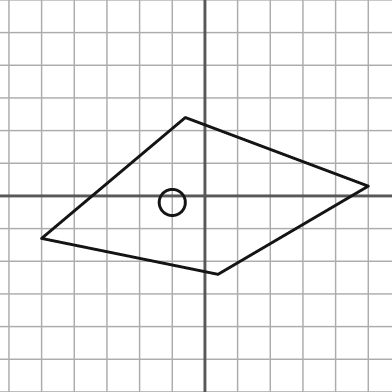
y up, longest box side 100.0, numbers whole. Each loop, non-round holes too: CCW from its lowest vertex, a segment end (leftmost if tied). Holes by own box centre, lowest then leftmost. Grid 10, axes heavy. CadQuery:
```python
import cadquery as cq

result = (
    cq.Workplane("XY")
    .moveTo(4.0, -24.0)
    .lineTo(50.0, 3.0)
    .lineTo(-6.0, 24.0)
    .lineTo(-50.0, -13.0)
    .close()
    .moveTo(-10.0, -2.0)
    .circle(4.0)
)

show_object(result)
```